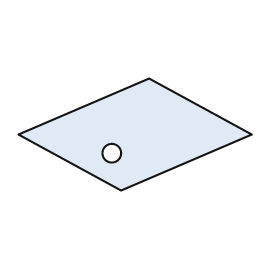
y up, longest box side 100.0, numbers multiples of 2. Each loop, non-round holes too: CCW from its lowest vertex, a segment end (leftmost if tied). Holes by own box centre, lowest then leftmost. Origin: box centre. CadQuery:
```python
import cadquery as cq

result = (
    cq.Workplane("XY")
    .moveTo(-6.0, -24.0)
    .lineTo(50.0, 0.0)
    .lineTo(6.0, 24.0)
    .lineTo(-50.0, 0.0)
    .close()
    .moveTo(-10.0, -8.0)
    .circle(4.0)
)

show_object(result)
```